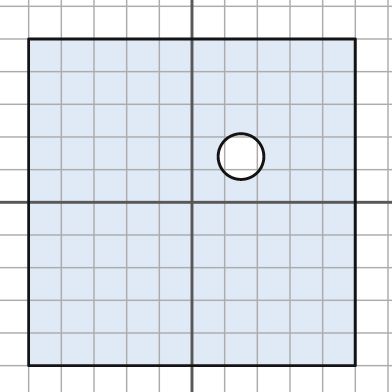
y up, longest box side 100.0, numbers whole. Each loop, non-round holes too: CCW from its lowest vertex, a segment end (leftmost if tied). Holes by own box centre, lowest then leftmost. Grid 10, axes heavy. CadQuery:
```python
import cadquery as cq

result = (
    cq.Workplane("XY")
    .moveTo(-50.0, -50.0)
    .lineTo(50.0, -50.0)
    .lineTo(50.0, 50.0)
    .lineTo(-50.0, 50.0)
    .close()
    .moveTo(15.0, 14.0)
    .circle(7.0)
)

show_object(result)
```